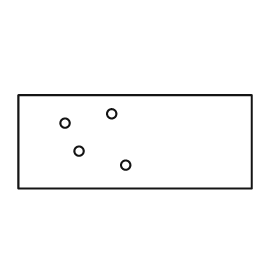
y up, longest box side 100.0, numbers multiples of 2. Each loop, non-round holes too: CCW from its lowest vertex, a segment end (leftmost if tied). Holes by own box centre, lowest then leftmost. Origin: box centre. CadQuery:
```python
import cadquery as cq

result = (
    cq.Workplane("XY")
    .moveTo(-50.0, -20.0)
    .lineTo(50.0, -20.0)
    .lineTo(50.0, 20.0)
    .lineTo(-50.0, 20.0)
    .close()
    .moveTo(-4.0, -10.0)
    .circle(2.0)
    .moveTo(-24.0, -4.0)
    .circle(2.0)
    .moveTo(-30.0, 8.0)
    .circle(2.0)
    .moveTo(-10.0, 12.0)
    .circle(2.0)
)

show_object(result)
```